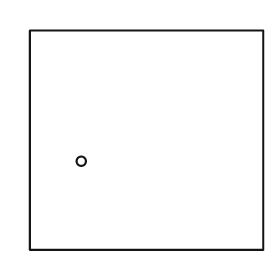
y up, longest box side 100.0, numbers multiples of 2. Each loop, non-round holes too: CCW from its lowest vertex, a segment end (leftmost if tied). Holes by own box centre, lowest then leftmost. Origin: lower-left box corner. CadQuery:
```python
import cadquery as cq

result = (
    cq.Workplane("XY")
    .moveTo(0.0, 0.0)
    .lineTo(100.0, 0.0)
    .lineTo(100.0, 94.0)
    .lineTo(0.0, 94.0)
    .close()
    .moveTo(22.0, 38.0)
    .circle(2.0)
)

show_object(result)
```